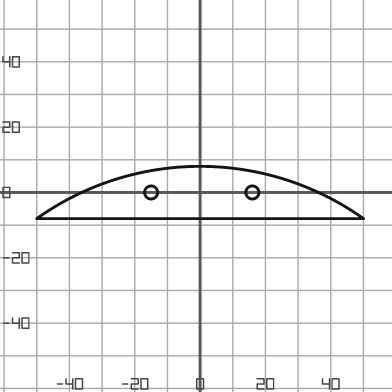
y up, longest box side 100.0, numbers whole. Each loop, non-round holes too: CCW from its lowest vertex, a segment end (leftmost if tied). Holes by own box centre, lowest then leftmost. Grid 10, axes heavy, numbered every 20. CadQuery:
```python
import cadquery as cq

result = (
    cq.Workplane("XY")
    .moveTo(-50.0, -8.0)
    .lineTo(50.0, -8.0)
    .threePointArc((0.0, 8.0), (-50.0, -8.0))
    .close()
    .moveTo(-15.0, 0.0)
    .circle(2.0)
    .moveTo(16.0, 0.0)
    .circle(2.0)
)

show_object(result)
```